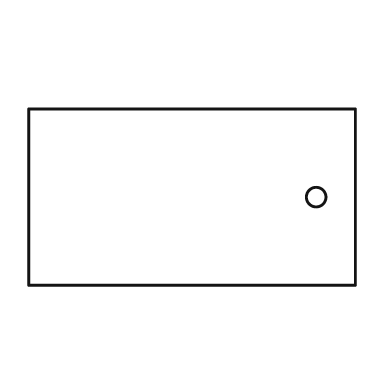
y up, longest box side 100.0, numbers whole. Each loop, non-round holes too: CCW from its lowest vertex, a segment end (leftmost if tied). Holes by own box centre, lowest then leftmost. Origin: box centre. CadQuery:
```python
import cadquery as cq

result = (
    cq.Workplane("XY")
    .moveTo(-50.0, -27.0)
    .lineTo(50.0, -27.0)
    .lineTo(50.0, 27.0)
    .lineTo(-50.0, 27.0)
    .close()
    .moveTo(38.0, 0.0)
    .circle(3.0)
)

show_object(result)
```